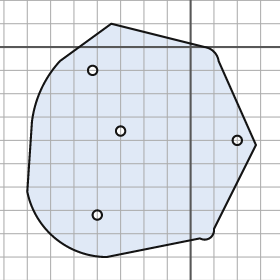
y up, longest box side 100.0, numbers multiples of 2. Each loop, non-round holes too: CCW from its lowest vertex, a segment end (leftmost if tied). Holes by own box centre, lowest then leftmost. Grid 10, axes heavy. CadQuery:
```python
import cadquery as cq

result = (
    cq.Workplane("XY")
    .moveTo(-36.0, -90.0)
    .lineTo(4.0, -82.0)
    .threePointArc((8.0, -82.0), (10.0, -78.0))
    .lineTo(28.0, -42.0)
    .lineTo(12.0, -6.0)
    .threePointArc((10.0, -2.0), (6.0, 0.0))
    .lineTo(-34.0, 10.0)
    .lineTo(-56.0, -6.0)
    .threePointArc((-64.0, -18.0), (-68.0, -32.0))
    .lineTo(-70.0, -62.0)
    .threePointArc((-58.0, -82.0), (-36.0, -90.0))
    .close()
    .moveTo(-40.0, -72.0)
    .circle(2.0)
    .moveTo(20.0, -40.0)
    .circle(2.0)
    .moveTo(-30.0, -36.0)
    .circle(2.0)
    .moveTo(-42.0, -10.0)
    .circle(2.0)
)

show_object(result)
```